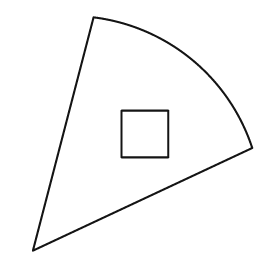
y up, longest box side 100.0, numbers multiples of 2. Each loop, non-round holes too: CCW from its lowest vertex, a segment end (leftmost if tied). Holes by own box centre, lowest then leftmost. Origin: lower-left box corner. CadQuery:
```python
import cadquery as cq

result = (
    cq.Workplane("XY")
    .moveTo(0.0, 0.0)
    .lineTo(94.0, 44.0)
    .threePointArc((68.0, 82.0), (26.0, 100.0))
    .close()
    .moveTo(38.0, 40.0)
    .lineTo(58.0, 40.0)
    .lineTo(58.0, 60.0)
    .lineTo(38.0, 60.0)
    .close()
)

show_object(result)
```